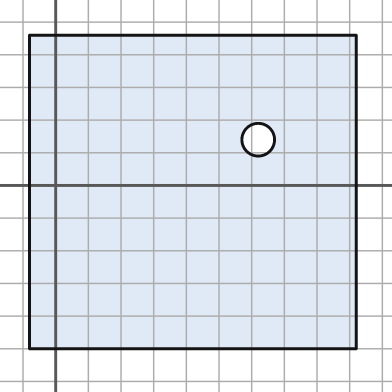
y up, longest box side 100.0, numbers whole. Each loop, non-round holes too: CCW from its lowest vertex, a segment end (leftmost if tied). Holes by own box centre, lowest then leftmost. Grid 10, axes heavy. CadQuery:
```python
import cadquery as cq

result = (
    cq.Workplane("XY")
    .moveTo(-8.0, -50.0)
    .lineTo(92.0, -50.0)
    .lineTo(92.0, 46.0)
    .lineTo(-8.0, 46.0)
    .close()
    .moveTo(62.0, 14.0)
    .circle(5.0)
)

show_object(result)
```